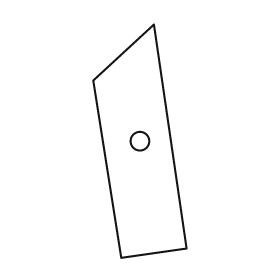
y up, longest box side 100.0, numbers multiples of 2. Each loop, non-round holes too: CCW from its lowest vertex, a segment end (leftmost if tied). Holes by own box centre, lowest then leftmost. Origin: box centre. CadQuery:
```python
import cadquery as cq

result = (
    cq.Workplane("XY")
    .moveTo(-8.0, -50.0)
    .lineTo(20.0, -46.0)
    .lineTo(6.0, 50.0)
    .lineTo(-20.0, 26.0)
    .close()
    .moveTo(0.0, 0.0)
    .circle(4.0)
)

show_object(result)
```